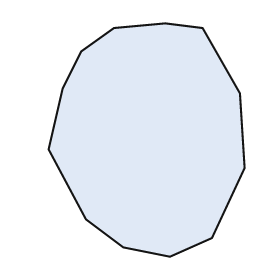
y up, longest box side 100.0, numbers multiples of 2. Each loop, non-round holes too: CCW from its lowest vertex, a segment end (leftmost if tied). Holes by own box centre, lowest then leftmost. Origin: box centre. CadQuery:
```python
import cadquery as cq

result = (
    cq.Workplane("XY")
    .moveTo(10.0, -50.0)
    .lineTo(28.0, -42.0)
    .lineTo(42.0, -12.0)
    .lineTo(40.0, 20.0)
    .lineTo(24.0, 48.0)
    .lineTo(8.0, 50.0)
    .lineTo(-14.0, 48.0)
    .lineTo(-28.0, 38.0)
    .lineTo(-36.0, 22.0)
    .lineTo(-42.0, -4.0)
    .lineTo(-26.0, -34.0)
    .lineTo(-10.0, -46.0)
    .close()
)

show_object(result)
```